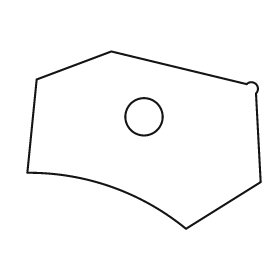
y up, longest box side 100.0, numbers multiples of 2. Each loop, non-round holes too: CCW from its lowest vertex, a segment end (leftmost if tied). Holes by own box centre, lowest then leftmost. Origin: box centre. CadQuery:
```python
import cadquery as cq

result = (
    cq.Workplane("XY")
    .moveTo(18.0, -38.0)
    .lineTo(50.0, -18.0)
    .lineTo(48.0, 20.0)
    .threePointArc((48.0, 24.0), (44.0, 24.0))
    .lineTo(-14.0, 38.0)
    .lineTo(-46.0, 26.0)
    .lineTo(-50.0, -14.0)
    .threePointArc((-14.0, -20.0), (18.0, -38.0))
    .close()
    .moveTo(0.0, 10.0)
    .circle(8.0)
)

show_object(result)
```